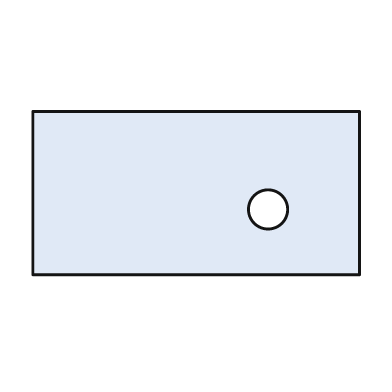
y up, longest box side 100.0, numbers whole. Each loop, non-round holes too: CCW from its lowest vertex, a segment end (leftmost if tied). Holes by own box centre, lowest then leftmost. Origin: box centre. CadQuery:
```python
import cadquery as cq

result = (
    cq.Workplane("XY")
    .moveTo(-50.0, -25.0)
    .lineTo(50.0, -25.0)
    .lineTo(50.0, 25.0)
    .lineTo(-50.0, 25.0)
    .close()
    .moveTo(22.0, -5.0)
    .circle(6.0)
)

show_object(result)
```